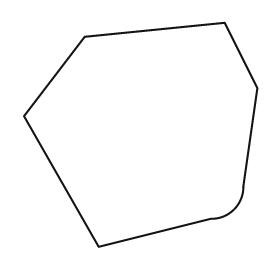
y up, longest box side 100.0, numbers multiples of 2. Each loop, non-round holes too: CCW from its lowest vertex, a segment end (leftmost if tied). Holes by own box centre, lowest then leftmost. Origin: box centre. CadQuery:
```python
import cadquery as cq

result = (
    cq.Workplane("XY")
    .moveTo(-18.0, -48.0)
    .lineTo(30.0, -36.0)
    .threePointArc((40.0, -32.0), (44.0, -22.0))
    .lineTo(50.0, 20.0)
    .lineTo(36.0, 48.0)
    .lineTo(-24.0, 42.0)
    .lineTo(-50.0, 8.0)
    .close()
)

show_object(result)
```